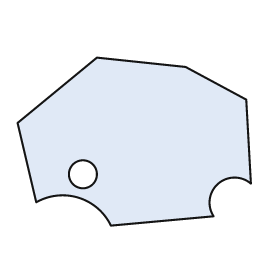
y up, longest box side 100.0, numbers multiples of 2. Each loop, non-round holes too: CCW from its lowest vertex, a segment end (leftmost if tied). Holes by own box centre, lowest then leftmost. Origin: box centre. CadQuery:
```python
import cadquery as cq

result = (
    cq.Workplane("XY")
    .moveTo(-10.0, -36.0)
    .lineTo(34.0, -32.0)
    .threePointArc((36.0, -18.0), (50.0, -18.0))
    .lineTo(48.0, 18.0)
    .lineTo(22.0, 32.0)
    .lineTo(-16.0, 36.0)
    .lineTo(-50.0, 8.0)
    .lineTo(-42.0, -26.0)
    .threePointArc((-24.0, -24.0), (-10.0, -36.0))
    .close()
    .moveTo(-22.0, -14.0)
    .circle(6.0)
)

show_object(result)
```